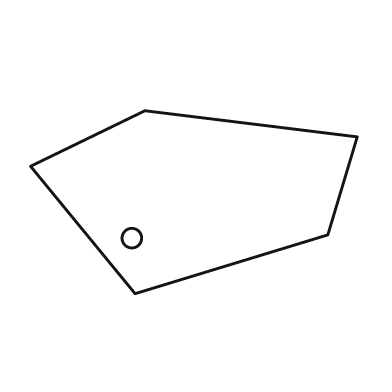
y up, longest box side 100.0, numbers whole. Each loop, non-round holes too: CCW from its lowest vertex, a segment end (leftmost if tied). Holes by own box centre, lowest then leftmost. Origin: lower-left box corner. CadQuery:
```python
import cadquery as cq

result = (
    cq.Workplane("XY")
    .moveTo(32.0, 0.0)
    .lineTo(91.0, 18.0)
    .lineTo(100.0, 48.0)
    .lineTo(35.0, 56.0)
    .lineTo(0.0, 39.0)
    .close()
    .moveTo(31.0, 17.0)
    .circle(3.0)
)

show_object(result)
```